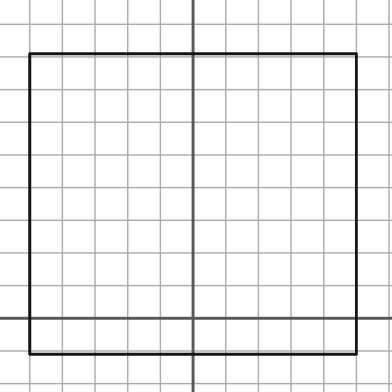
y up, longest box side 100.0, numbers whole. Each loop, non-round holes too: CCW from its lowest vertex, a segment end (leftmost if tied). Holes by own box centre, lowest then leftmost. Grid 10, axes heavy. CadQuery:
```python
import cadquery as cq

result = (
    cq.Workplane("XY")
    .moveTo(-50.0, -11.0)
    .lineTo(50.0, -11.0)
    .lineTo(50.0, 81.0)
    .lineTo(-50.0, 81.0)
    .close()
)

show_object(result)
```